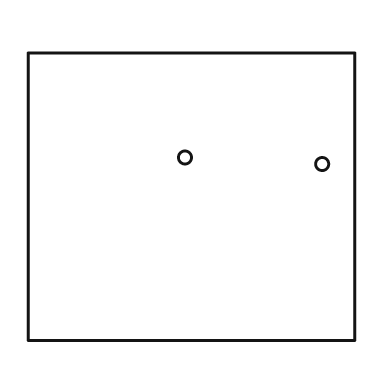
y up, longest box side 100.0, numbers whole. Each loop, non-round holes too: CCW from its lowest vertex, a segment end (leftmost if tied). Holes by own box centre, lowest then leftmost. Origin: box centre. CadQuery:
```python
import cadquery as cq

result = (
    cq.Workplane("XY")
    .moveTo(-50.0, -44.0)
    .lineTo(50.0, -44.0)
    .lineTo(50.0, 44.0)
    .lineTo(-50.0, 44.0)
    .close()
    .moveTo(40.0, 10.0)
    .circle(2.0)
    .moveTo(-2.0, 12.0)
    .circle(2.0)
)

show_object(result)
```